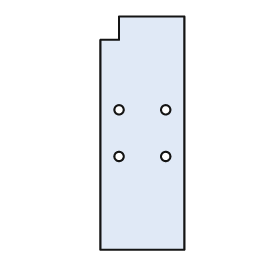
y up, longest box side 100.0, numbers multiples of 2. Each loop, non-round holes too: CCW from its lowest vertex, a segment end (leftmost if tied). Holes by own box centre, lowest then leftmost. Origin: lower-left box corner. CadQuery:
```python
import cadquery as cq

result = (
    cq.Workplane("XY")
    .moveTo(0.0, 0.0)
    .lineTo(36.0, 0.0)
    .lineTo(36.0, 100.0)
    .lineTo(8.0, 100.0)
    .lineTo(8.0, 90.0)
    .lineTo(0.0, 90.0)
    .close()
    .moveTo(8.0, 40.0)
    .circle(2.0)
    .moveTo(28.0, 40.0)
    .circle(2.0)
    .moveTo(8.0, 60.0)
    .circle(2.0)
    .moveTo(28.0, 60.0)
    .circle(2.0)
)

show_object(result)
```